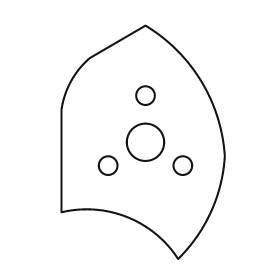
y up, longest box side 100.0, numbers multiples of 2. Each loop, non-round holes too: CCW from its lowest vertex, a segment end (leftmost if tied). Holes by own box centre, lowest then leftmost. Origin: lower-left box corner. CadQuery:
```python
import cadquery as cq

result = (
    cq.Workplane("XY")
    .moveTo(50.0, 0.0)
    .threePointArc((64.0, 20.0), (70.0, 44.0))
    .threePointArc((60.0, 76.0), (36.0, 100.0))
    .lineTo(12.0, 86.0)
    .threePointArc((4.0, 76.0), (0.0, 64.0))
    .lineTo(0.0, 20.0)
    .threePointArc((28.0, 18.0), (50.0, 0.0))
    .close()
    .moveTo(20.0, 40.0)
    .circle(4.0)
    .moveTo(52.0, 40.0)
    .circle(4.0)
    .moveTo(36.0, 50.0)
    .circle(8.0)
    .moveTo(36.0, 70.0)
    .circle(4.0)
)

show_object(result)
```